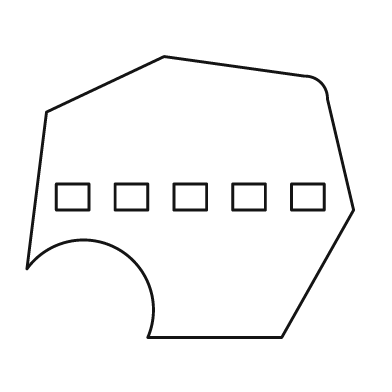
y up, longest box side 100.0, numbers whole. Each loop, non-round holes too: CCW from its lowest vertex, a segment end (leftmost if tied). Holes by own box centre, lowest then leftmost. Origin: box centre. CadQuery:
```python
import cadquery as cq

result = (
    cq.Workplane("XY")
    .moveTo(-13.0, -43.0)
    .lineTo(28.0, -43.0)
    .lineTo(50.0, -4.0)
    .lineTo(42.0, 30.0)
    .threePointArc((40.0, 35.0), (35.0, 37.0))
    .lineTo(-8.0, 43.0)
    .lineTo(-44.0, 26.0)
    .lineTo(-50.0, -22.0)
    .threePointArc((-22.0, -16.0), (-13.0, -43.0))
    .close()
    .moveTo(-41.0, -4.0)
    .lineTo(-31.0, -4.0)
    .lineTo(-31.0, 4.0)
    .lineTo(-41.0, 4.0)
    .close()
    .moveTo(-23.0, -4.0)
    .lineTo(-13.0, -4.0)
    .lineTo(-13.0, 4.0)
    .lineTo(-23.0, 4.0)
    .close()
    .moveTo(-5.0, -4.0)
    .lineTo(5.0, -4.0)
    .lineTo(5.0, 4.0)
    .lineTo(-5.0, 4.0)
    .close()
    .moveTo(13.0, -4.0)
    .lineTo(23.0, -4.0)
    .lineTo(23.0, 4.0)
    .lineTo(13.0, 4.0)
    .close()
    .moveTo(31.0, -4.0)
    .lineTo(41.0, -4.0)
    .lineTo(41.0, 4.0)
    .lineTo(31.0, 4.0)
    .close()
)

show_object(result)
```